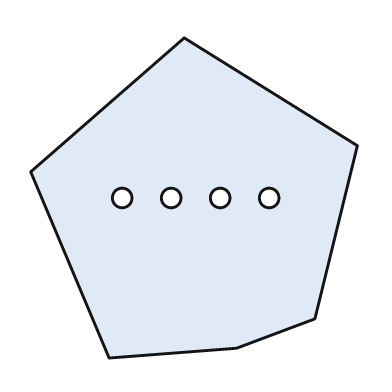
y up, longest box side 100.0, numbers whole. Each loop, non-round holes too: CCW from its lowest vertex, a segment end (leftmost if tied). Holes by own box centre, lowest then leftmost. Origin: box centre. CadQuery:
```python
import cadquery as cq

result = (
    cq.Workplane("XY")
    .moveTo(-26.0, -49.0)
    .lineTo(13.0, -46.0)
    .lineTo(37.0, -37.0)
    .lineTo(50.0, 16.0)
    .lineTo(-3.0, 49.0)
    .lineTo(-50.0, 8.0)
    .close()
    .moveTo(-22.0, 0.0)
    .circle(3.0)
    .moveTo(-7.0, 0.0)
    .circle(3.0)
    .moveTo(8.0, 0.0)
    .circle(3.0)
    .moveTo(23.0, 0.0)
    .circle(3.0)
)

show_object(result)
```